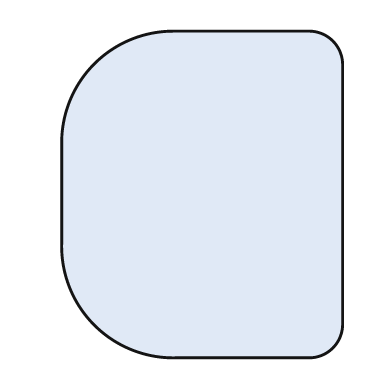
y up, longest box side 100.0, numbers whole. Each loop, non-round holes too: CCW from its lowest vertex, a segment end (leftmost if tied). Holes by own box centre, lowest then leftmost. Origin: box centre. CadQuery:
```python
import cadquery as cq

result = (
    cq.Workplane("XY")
    .moveTo(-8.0, -50.0)
    .lineTo(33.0, -50.0)
    .threePointArc((40.0, -47.0), (43.0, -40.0))
    .lineTo(43.0, 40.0)
    .threePointArc((40.0, 47.0), (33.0, 50.0))
    .lineTo(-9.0, 50.0)
    .threePointArc((-33.0, 40.0), (-43.0, 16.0))
    .lineTo(-43.0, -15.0)
    .threePointArc((-33.0, -40.0), (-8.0, -50.0))
    .close()
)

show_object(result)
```